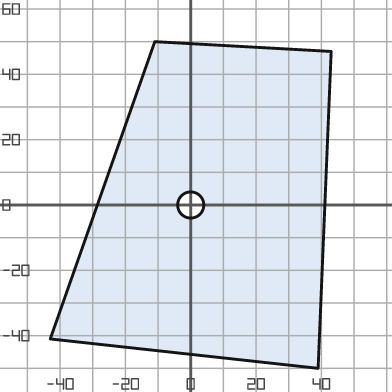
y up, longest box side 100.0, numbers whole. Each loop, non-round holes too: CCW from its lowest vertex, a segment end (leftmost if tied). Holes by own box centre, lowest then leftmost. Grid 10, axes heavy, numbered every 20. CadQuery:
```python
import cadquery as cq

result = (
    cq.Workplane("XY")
    .moveTo(39.0, -50.0)
    .lineTo(43.0, 47.0)
    .lineTo(-11.0, 50.0)
    .lineTo(-43.0, -41.0)
    .close()
    .moveTo(0.0, 0.0)
    .circle(4.0)
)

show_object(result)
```